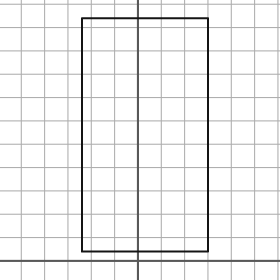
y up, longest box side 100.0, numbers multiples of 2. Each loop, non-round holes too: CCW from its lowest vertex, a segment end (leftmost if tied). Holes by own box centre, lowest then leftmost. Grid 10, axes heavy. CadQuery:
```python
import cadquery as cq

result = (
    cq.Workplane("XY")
    .moveTo(-24.0, 4.0)
    .lineTo(30.0, 4.0)
    .lineTo(30.0, 104.0)
    .lineTo(-24.0, 104.0)
    .close()
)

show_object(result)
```